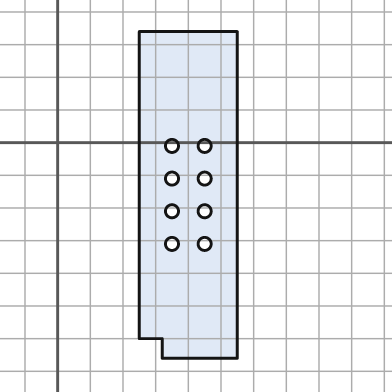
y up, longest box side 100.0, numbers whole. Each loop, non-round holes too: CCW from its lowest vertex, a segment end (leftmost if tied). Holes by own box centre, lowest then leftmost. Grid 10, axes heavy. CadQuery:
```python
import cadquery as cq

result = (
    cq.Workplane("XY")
    .moveTo(32.0, -66.0)
    .lineTo(55.0, -66.0)
    .lineTo(55.0, 34.0)
    .lineTo(25.0, 34.0)
    .lineTo(25.0, -60.0)
    .lineTo(32.0, -60.0)
    .close()
    .moveTo(35.0, -31.0)
    .circle(2.0)
    .moveTo(45.0, -31.0)
    .circle(2.0)
    .moveTo(35.0, -21.0)
    .circle(2.0)
    .moveTo(45.0, -21.0)
    .circle(2.0)
    .moveTo(35.0, -11.0)
    .circle(2.0)
    .moveTo(45.0, -11.0)
    .circle(2.0)
    .moveTo(35.0, -1.0)
    .circle(2.0)
    .moveTo(45.0, -1.0)
    .circle(2.0)
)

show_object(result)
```